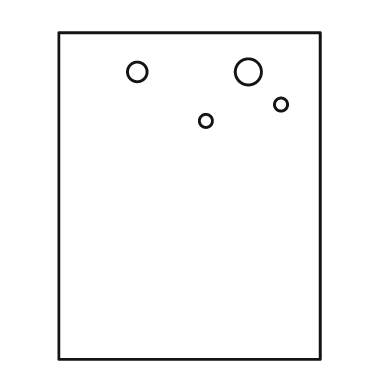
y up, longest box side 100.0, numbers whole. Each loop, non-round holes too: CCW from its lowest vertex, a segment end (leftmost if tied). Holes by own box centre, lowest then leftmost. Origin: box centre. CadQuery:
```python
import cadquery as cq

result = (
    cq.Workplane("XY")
    .moveTo(-40.0, -50.0)
    .lineTo(40.0, -50.0)
    .lineTo(40.0, 50.0)
    .lineTo(-40.0, 50.0)
    .close()
    .moveTo(5.0, 23.0)
    .circle(2.0)
    .moveTo(28.0, 28.0)
    .circle(2.0)
    .moveTo(-16.0, 38.0)
    .circle(3.0)
    .moveTo(18.0, 38.0)
    .circle(4.0)
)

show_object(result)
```